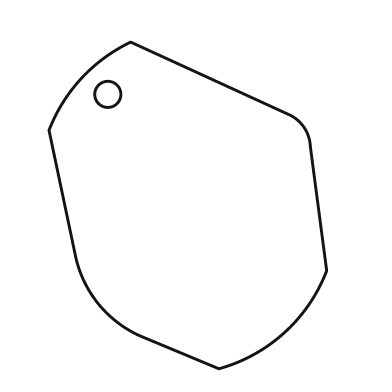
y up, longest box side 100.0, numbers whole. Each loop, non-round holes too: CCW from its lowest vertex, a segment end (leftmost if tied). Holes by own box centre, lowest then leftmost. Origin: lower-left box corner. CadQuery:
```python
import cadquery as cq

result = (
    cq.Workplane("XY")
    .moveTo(52.0, 0.0)
    .threePointArc((72.0, 11.0), (85.0, 30.0))
    .lineTo(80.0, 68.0)
    .threePointArc((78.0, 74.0), (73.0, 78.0))
    .lineTo(25.0, 100.0)
    .threePointArc((10.0, 89.0), (0.0, 73.0))
    .lineTo(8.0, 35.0)
    .threePointArc((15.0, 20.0), (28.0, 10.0))
    .close()
    .moveTo(18.0, 84.0)
    .circle(4.0)
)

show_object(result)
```